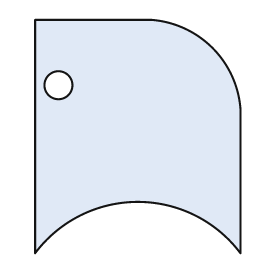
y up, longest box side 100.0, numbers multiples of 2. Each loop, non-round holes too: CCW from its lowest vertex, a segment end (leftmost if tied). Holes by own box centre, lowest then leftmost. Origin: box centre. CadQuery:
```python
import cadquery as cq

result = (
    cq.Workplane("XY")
    .moveTo(-44.0, -50.0)
    .threePointArc((0.0, -28.0), (44.0, -50.0))
    .lineTo(44.0, 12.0)
    .threePointArc((32.0, 38.0), (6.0, 50.0))
    .lineTo(-44.0, 50.0)
    .close()
    .moveTo(-34.0, 22.0)
    .circle(6.0)
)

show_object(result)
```